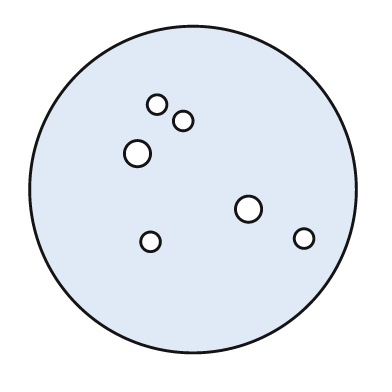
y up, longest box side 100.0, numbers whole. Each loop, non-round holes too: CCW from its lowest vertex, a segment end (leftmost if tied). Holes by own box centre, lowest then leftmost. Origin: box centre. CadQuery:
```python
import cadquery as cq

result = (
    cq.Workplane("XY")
    .moveTo(0.0, 0.0)
    .circle(50.0)
    .moveTo(-13.0, -16.0)
    .circle(3.0)
    .moveTo(34.0, -15.0)
    .circle(3.0)
    .moveTo(17.0, -6.0)
    .circle(4.0)
    .moveTo(-17.0, 11.0)
    .circle(4.0)
    .moveTo(-3.0, 21.0)
    .circle(3.0)
    .moveTo(-11.0, 26.0)
    .circle(3.0)
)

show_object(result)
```